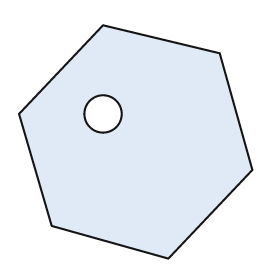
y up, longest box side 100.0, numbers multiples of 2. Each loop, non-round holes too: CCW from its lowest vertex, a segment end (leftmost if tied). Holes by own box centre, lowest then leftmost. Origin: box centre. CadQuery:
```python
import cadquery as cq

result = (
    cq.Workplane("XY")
    .moveTo(14.0, -50.0)
    .lineTo(50.0, -12.0)
    .lineTo(36.0, 38.0)
    .lineTo(-14.0, 50.0)
    .lineTo(-50.0, 12.0)
    .lineTo(-36.0, -36.0)
    .close()
    .moveTo(-14.0, 12.0)
    .circle(8.0)
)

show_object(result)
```